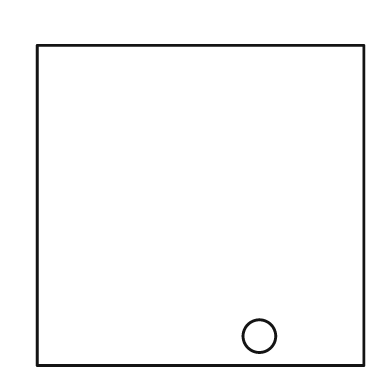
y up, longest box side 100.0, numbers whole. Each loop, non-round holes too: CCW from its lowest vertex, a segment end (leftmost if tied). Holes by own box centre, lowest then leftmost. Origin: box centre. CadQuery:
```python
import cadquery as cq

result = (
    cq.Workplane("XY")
    .moveTo(-50.0, -49.0)
    .lineTo(50.0, -49.0)
    .lineTo(50.0, 49.0)
    .lineTo(-50.0, 49.0)
    .close()
    .moveTo(18.0, -40.0)
    .circle(5.0)
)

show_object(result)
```